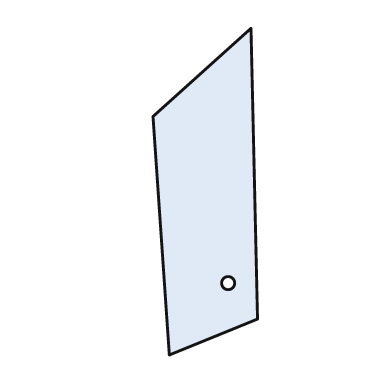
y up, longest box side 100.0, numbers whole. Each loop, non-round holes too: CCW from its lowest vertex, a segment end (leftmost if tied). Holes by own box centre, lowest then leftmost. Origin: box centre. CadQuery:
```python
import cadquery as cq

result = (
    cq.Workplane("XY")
    .moveTo(-11.0, -50.0)
    .lineTo(16.0, -39.0)
    .lineTo(14.0, 50.0)
    .lineTo(-16.0, 23.0)
    .close()
    .moveTo(7.0, -28.0)
    .circle(2.0)
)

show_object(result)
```